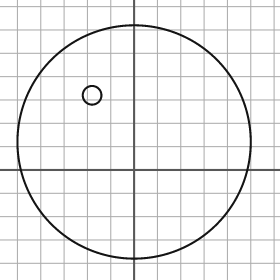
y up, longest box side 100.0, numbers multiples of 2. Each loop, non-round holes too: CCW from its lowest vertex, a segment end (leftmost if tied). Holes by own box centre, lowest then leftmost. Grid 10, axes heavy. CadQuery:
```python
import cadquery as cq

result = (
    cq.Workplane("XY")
    .moveTo(0.0, 12.0)
    .circle(50.0)
    .moveTo(-18.0, 32.0)
    .circle(4.0)
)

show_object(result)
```